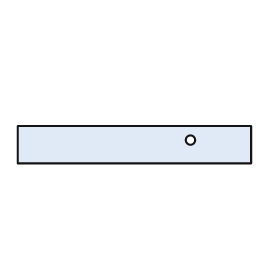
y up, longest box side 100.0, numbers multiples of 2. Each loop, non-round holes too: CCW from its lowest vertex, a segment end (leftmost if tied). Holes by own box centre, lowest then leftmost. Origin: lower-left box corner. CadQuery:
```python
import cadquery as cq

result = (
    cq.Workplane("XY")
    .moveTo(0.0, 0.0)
    .lineTo(100.0, 0.0)
    .lineTo(100.0, 16.0)
    .lineTo(0.0, 16.0)
    .close()
    .moveTo(74.0, 10.0)
    .circle(2.0)
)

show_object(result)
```